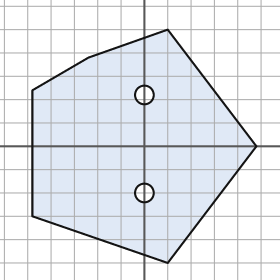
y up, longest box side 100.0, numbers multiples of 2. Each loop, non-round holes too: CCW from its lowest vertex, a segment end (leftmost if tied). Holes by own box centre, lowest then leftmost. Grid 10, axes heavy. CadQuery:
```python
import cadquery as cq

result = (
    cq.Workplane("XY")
    .moveTo(10.0, -50.0)
    .lineTo(48.0, 0.0)
    .lineTo(10.0, 50.0)
    .lineTo(-24.0, 38.0)
    .lineTo(-48.0, 24.0)
    .lineTo(-48.0, -30.0)
    .close()
    .moveTo(0.0, -20.0)
    .circle(4.0)
    .moveTo(0.0, 22.0)
    .circle(4.0)
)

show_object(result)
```